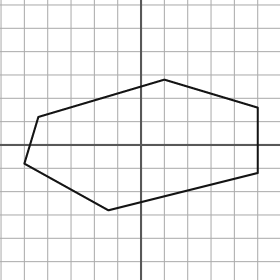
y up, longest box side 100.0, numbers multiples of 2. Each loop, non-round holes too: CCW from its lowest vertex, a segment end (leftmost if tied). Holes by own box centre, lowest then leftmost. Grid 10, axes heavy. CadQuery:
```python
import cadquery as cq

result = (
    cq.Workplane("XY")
    .moveTo(-14.0, -28.0)
    .lineTo(50.0, -12.0)
    .lineTo(50.0, 16.0)
    .lineTo(10.0, 28.0)
    .lineTo(-44.0, 12.0)
    .lineTo(-50.0, -8.0)
    .close()
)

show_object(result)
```